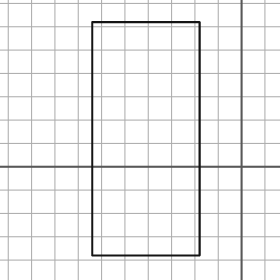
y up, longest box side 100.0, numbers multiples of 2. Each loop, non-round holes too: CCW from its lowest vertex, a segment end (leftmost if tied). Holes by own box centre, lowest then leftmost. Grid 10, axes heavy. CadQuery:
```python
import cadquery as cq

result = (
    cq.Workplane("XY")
    .moveTo(-64.0, -38.0)
    .lineTo(-18.0, -38.0)
    .lineTo(-18.0, 62.0)
    .lineTo(-64.0, 62.0)
    .close()
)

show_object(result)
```